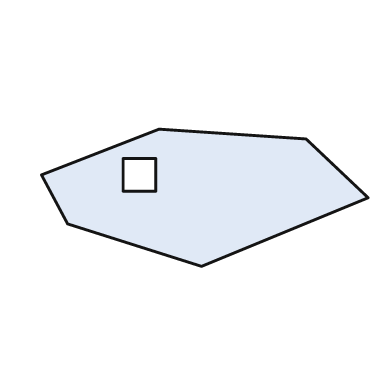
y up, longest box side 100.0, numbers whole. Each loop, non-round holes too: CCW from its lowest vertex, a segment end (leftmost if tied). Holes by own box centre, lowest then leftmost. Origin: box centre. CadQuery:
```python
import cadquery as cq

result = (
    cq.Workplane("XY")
    .moveTo(-1.0, -21.0)
    .lineTo(50.0, 0.0)
    .lineTo(31.0, 18.0)
    .lineTo(-14.0, 21.0)
    .lineTo(-50.0, 7.0)
    .lineTo(-42.0, -8.0)
    .close()
    .moveTo(-25.0, 2.0)
    .lineTo(-15.0, 2.0)
    .lineTo(-15.0, 12.0)
    .lineTo(-25.0, 12.0)
    .close()
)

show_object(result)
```